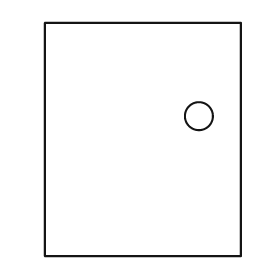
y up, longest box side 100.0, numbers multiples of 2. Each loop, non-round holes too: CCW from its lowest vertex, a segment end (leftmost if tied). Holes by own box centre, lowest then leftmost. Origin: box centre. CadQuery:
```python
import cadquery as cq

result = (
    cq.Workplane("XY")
    .moveTo(-42.0, -50.0)
    .lineTo(42.0, -50.0)
    .lineTo(42.0, 50.0)
    .lineTo(-42.0, 50.0)
    .close()
    .moveTo(24.0, 10.0)
    .circle(6.0)
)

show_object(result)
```